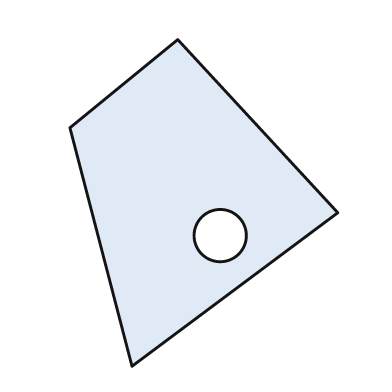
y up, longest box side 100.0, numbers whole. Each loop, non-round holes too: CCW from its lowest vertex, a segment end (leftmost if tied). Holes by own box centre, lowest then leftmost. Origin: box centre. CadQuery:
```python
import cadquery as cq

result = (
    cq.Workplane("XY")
    .moveTo(-22.0, -50.0)
    .lineTo(41.0, -3.0)
    .lineTo(-8.0, 50.0)
    .lineTo(-41.0, 23.0)
    .close()
    .moveTo(5.0, -10.0)
    .circle(8.0)
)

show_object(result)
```